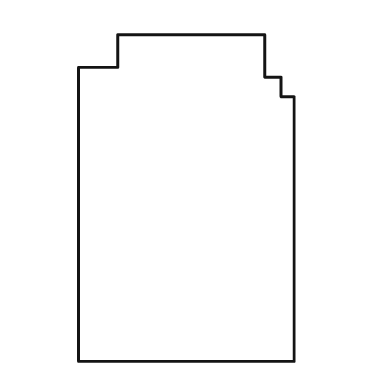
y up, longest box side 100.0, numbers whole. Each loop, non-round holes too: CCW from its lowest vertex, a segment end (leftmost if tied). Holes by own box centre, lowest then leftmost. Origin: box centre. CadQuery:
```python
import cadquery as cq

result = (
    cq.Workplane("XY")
    .moveTo(-33.0, -50.0)
    .lineTo(33.0, -50.0)
    .lineTo(33.0, 31.0)
    .lineTo(29.0, 31.0)
    .lineTo(29.0, 37.0)
    .lineTo(24.0, 37.0)
    .lineTo(24.0, 50.0)
    .lineTo(-21.0, 50.0)
    .lineTo(-21.0, 40.0)
    .lineTo(-33.0, 40.0)
    .close()
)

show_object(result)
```